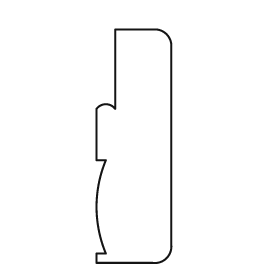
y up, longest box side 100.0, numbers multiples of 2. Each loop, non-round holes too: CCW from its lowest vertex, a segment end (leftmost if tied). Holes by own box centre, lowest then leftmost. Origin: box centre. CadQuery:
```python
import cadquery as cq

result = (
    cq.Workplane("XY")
    .moveTo(-16.0, -50.0)
    .lineTo(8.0, -50.0)
    .threePointArc((14.0, -48.0), (16.0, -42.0))
    .lineTo(16.0, 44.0)
    .threePointArc((14.0, 48.0), (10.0, 50.0))
    .lineTo(-8.0, 50.0)
    .lineTo(-8.0, 16.0)
    .threePointArc((-12.0, 18.0), (-16.0, 16.0))
    .lineTo(-16.0, -6.0)
    .lineTo(-12.0, -6.0)
    .threePointArc((-16.0, -26.0), (-12.0, -46.0))
    .lineTo(-16.0, -46.0)
    .close()
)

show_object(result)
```